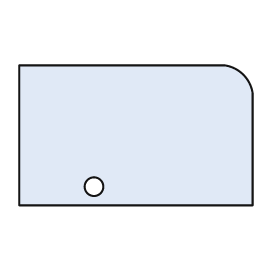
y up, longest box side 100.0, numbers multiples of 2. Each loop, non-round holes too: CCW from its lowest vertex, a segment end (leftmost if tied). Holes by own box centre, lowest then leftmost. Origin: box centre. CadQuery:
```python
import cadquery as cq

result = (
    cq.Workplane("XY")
    .moveTo(-50.0, -30.0)
    .lineTo(50.0, -30.0)
    .lineTo(50.0, 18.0)
    .threePointArc((46.0, 26.0), (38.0, 30.0))
    .lineTo(-50.0, 30.0)
    .close()
    .moveTo(-18.0, -22.0)
    .circle(4.0)
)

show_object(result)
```